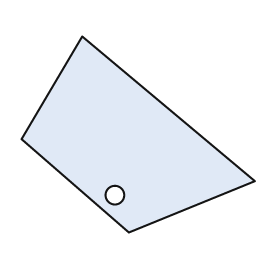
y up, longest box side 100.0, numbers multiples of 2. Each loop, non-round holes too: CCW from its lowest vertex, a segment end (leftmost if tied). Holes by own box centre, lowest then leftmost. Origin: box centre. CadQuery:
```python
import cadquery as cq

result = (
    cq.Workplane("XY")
    .moveTo(-4.0, -42.0)
    .lineTo(50.0, -20.0)
    .lineTo(-24.0, 42.0)
    .lineTo(-50.0, -2.0)
    .close()
    .moveTo(-10.0, -26.0)
    .circle(4.0)
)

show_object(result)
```